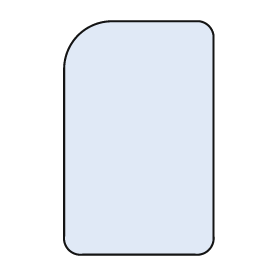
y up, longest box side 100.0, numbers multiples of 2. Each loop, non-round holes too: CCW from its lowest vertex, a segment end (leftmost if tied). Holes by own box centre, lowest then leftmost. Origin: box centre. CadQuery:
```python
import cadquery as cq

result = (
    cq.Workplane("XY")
    .moveTo(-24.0, -50.0)
    .lineTo(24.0, -50.0)
    .threePointArc((30.0, -48.0), (32.0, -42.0))
    .lineTo(32.0, 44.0)
    .threePointArc((30.0, 48.0), (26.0, 50.0))
    .lineTo(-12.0, 50.0)
    .threePointArc((-26.0, 44.0), (-32.0, 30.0))
    .lineTo(-32.0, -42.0)
    .threePointArc((-30.0, -48.0), (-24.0, -50.0))
    .close()
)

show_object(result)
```